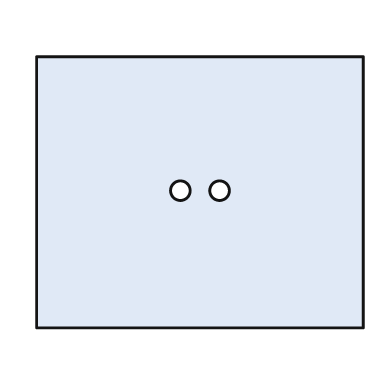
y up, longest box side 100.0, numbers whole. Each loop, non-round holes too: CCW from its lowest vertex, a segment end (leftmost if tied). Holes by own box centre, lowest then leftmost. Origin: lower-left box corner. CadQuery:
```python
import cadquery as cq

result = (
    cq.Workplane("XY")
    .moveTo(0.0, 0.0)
    .lineTo(100.0, 0.0)
    .lineTo(100.0, 83.0)
    .lineTo(0.0, 83.0)
    .close()
    .moveTo(44.0, 42.0)
    .circle(3.0)
    .moveTo(56.0, 42.0)
    .circle(3.0)
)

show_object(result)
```